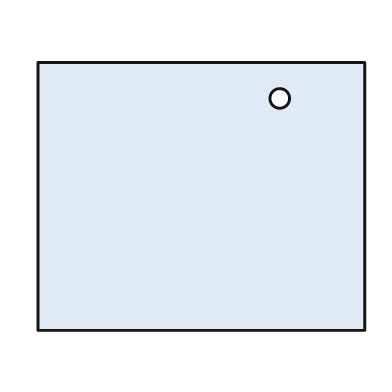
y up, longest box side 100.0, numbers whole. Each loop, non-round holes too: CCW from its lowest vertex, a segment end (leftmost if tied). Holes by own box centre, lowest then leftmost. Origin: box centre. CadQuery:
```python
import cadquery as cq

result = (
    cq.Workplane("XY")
    .moveTo(-50.0, -41.0)
    .lineTo(50.0, -41.0)
    .lineTo(50.0, 41.0)
    .lineTo(-50.0, 41.0)
    .close()
    .moveTo(24.0, 30.0)
    .circle(3.0)
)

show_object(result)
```